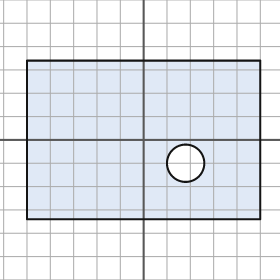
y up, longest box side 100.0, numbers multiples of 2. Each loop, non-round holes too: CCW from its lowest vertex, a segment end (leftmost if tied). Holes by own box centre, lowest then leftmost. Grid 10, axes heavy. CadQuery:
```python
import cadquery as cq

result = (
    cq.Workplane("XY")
    .moveTo(-50.0, -34.0)
    .lineTo(50.0, -34.0)
    .lineTo(50.0, 34.0)
    .lineTo(-50.0, 34.0)
    .close()
    .moveTo(18.0, -10.0)
    .circle(8.0)
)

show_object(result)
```